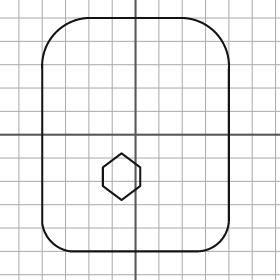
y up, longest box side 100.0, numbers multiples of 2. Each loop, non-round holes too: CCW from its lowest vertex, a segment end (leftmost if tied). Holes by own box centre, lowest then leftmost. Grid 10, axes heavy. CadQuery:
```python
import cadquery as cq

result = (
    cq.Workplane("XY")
    .moveTo(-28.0, -50.0)
    .lineTo(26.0, -50.0)
    .threePointArc((36.0, -46.0), (40.0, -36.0))
    .lineTo(40.0, 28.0)
    .threePointArc((34.0, 44.0), (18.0, 50.0))
    .lineTo(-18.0, 50.0)
    .threePointArc((-34.0, 44.0), (-40.0, 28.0))
    .lineTo(-40.0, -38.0)
    .threePointArc((-36.0, -46.0), (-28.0, -50.0))
    .close()
    .moveTo(-6.0, -28.0)
    .lineTo(2.0, -22.0)
    .lineTo(2.0, -14.0)
    .lineTo(-6.0, -8.0)
    .lineTo(-14.0, -14.0)
    .lineTo(-14.0, -22.0)
    .close()
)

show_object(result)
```